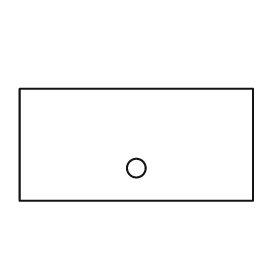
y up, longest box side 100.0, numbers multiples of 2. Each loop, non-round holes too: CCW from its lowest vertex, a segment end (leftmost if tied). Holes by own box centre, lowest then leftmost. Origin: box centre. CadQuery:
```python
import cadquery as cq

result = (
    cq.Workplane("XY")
    .moveTo(-50.0, -24.0)
    .lineTo(50.0, -24.0)
    .lineTo(50.0, 24.0)
    .lineTo(-50.0, 24.0)
    .close()
    .moveTo(0.0, -10.0)
    .circle(4.0)
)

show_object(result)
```